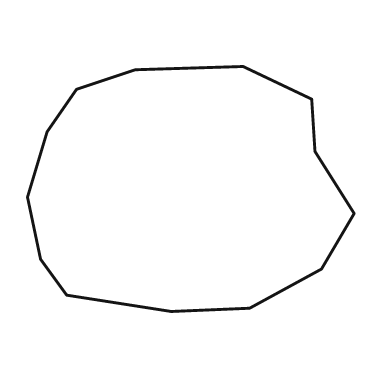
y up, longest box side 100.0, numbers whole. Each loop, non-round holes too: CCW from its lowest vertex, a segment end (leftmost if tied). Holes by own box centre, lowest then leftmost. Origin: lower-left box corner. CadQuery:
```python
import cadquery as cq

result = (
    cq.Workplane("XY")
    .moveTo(44.0, 0.0)
    .lineTo(68.0, 1.0)
    .lineTo(90.0, 13.0)
    .lineTo(100.0, 30.0)
    .lineTo(88.0, 49.0)
    .lineTo(87.0, 65.0)
    .lineTo(66.0, 75.0)
    .lineTo(33.0, 74.0)
    .lineTo(15.0, 68.0)
    .lineTo(6.0, 55.0)
    .lineTo(0.0, 35.0)
    .lineTo(4.0, 16.0)
    .lineTo(12.0, 5.0)
    .close()
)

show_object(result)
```